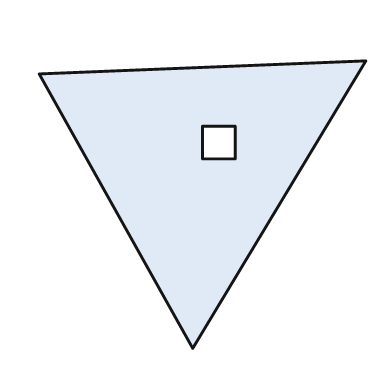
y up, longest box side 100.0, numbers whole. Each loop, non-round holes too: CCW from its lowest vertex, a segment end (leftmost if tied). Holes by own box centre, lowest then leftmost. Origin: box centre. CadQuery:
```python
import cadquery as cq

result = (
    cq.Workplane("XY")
    .moveTo(-3.0, -44.0)
    .lineTo(50.0, 44.0)
    .lineTo(-50.0, 40.0)
    .close()
    .moveTo(0.0, 14.0)
    .lineTo(10.0, 14.0)
    .lineTo(10.0, 24.0)
    .lineTo(0.0, 24.0)
    .close()
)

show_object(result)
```